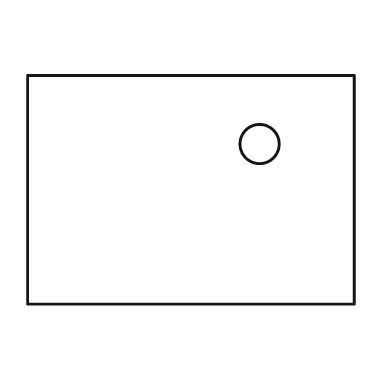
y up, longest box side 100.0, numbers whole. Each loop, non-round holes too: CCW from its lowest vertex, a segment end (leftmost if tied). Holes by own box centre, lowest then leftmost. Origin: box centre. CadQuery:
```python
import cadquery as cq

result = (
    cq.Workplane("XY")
    .moveTo(-50.0, -35.0)
    .lineTo(50.0, -35.0)
    .lineTo(50.0, 35.0)
    .lineTo(-50.0, 35.0)
    .close()
    .moveTo(21.0, 14.0)
    .circle(6.0)
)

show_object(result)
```